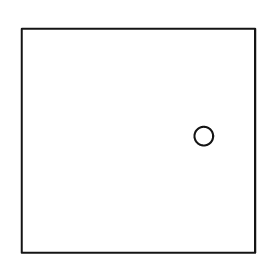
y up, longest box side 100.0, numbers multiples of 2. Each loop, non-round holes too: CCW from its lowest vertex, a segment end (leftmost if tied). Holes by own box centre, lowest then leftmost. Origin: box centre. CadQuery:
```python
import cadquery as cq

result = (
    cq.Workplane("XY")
    .moveTo(-50.0, -48.0)
    .lineTo(50.0, -48.0)
    .lineTo(50.0, 48.0)
    .lineTo(-50.0, 48.0)
    .close()
    .moveTo(28.0, 2.0)
    .circle(4.0)
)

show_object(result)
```